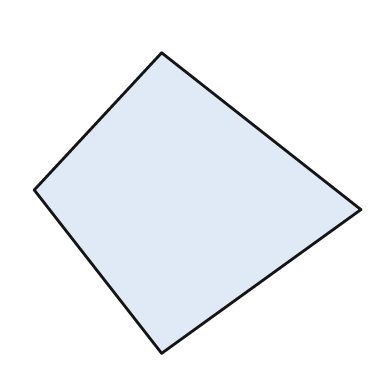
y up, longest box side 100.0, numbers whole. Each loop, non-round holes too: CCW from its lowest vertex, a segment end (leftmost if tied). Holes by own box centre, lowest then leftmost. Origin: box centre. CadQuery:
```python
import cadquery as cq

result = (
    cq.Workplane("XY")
    .moveTo(-11.0, -46.0)
    .lineTo(50.0, -2.0)
    .lineTo(-11.0, 46.0)
    .lineTo(-50.0, 4.0)
    .close()
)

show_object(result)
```